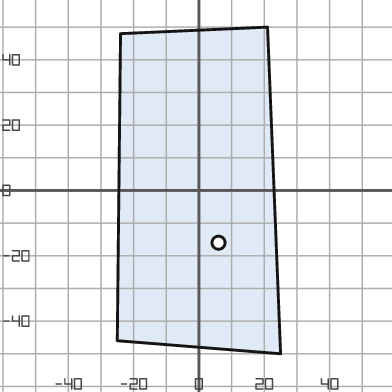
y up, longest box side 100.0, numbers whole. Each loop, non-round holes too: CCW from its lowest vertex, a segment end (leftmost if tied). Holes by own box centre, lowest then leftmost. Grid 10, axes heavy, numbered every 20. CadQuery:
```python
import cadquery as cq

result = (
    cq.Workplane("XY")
    .moveTo(25.0, -50.0)
    .lineTo(21.0, 50.0)
    .lineTo(-24.0, 48.0)
    .lineTo(-25.0, -46.0)
    .close()
    .moveTo(6.0, -16.0)
    .circle(2.0)
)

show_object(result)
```